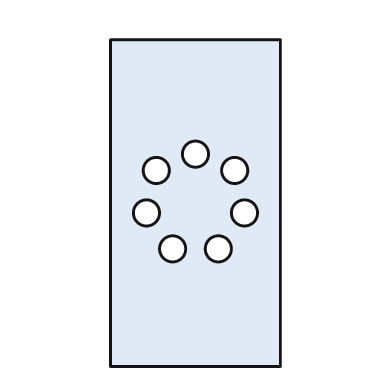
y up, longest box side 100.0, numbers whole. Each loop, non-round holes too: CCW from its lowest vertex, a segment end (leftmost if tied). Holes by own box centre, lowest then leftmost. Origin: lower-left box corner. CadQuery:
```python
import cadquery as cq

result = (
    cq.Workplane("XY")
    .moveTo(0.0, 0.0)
    .lineTo(52.0, 0.0)
    .lineTo(52.0, 100.0)
    .lineTo(0.0, 100.0)
    .close()
    .moveTo(19.0, 36.0)
    .circle(4.0)
    .moveTo(33.0, 36.0)
    .circle(4.0)
    .moveTo(11.0, 47.0)
    .circle(4.0)
    .moveTo(41.0, 47.0)
    .circle(4.0)
    .moveTo(14.0, 60.0)
    .circle(4.0)
    .moveTo(38.0, 60.0)
    .circle(4.0)
    .moveTo(26.0, 65.0)
    .circle(4.0)
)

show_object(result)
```